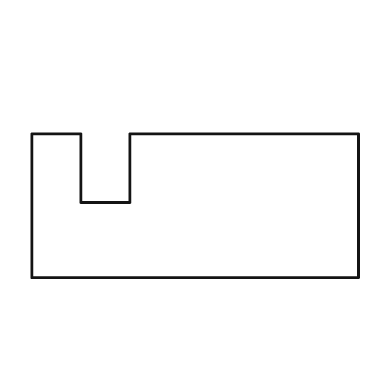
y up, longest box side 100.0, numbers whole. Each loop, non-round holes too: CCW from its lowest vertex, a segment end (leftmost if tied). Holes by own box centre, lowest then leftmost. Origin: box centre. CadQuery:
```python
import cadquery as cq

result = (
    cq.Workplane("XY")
    .moveTo(-50.0, -22.0)
    .lineTo(50.0, -22.0)
    .lineTo(50.0, 22.0)
    .lineTo(-20.0, 22.0)
    .lineTo(-20.0, 1.0)
    .lineTo(-35.0, 1.0)
    .lineTo(-35.0, 22.0)
    .lineTo(-50.0, 22.0)
    .close()
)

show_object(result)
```